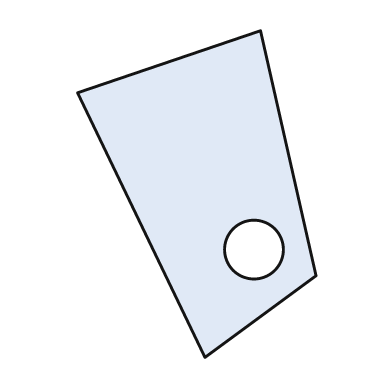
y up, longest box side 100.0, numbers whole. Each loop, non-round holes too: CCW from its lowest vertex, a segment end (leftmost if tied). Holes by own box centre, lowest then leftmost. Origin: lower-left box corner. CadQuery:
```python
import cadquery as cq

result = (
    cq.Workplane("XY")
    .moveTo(39.0, 0.0)
    .lineTo(73.0, 25.0)
    .lineTo(56.0, 100.0)
    .lineTo(0.0, 81.0)
    .close()
    .moveTo(54.0, 33.0)
    .circle(9.0)
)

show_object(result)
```